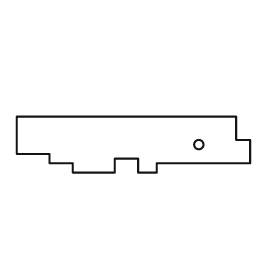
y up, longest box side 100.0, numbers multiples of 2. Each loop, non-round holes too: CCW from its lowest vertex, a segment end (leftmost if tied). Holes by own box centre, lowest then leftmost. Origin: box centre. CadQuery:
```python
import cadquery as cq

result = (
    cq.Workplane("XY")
    .moveTo(-26.0, -12.0)
    .lineTo(-8.0, -12.0)
    .lineTo(-8.0, -6.0)
    .lineTo(2.0, -6.0)
    .lineTo(2.0, -12.0)
    .lineTo(10.0, -12.0)
    .lineTo(10.0, -8.0)
    .lineTo(50.0, -8.0)
    .lineTo(50.0, 2.0)
    .lineTo(44.0, 2.0)
    .lineTo(44.0, 12.0)
    .lineTo(-50.0, 12.0)
    .lineTo(-50.0, -4.0)
    .lineTo(-36.0, -4.0)
    .lineTo(-36.0, -8.0)
    .lineTo(-26.0, -8.0)
    .close()
    .moveTo(28.0, 0.0)
    .circle(2.0)
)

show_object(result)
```